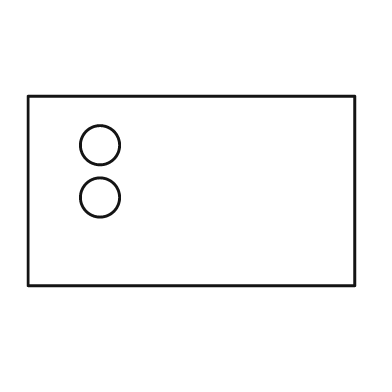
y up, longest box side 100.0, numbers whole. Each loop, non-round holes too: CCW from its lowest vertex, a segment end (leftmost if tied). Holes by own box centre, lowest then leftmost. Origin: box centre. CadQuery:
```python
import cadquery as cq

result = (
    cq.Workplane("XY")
    .moveTo(-50.0, -29.0)
    .lineTo(50.0, -29.0)
    .lineTo(50.0, 29.0)
    .lineTo(-50.0, 29.0)
    .close()
    .moveTo(-28.0, -2.0)
    .circle(6.0)
    .moveTo(-28.0, 14.0)
    .circle(6.0)
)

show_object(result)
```